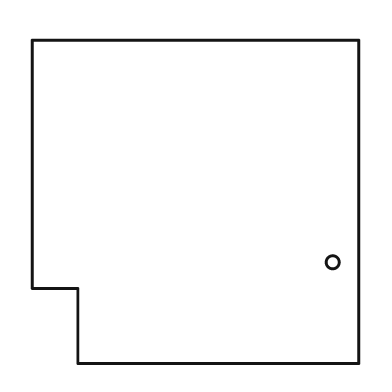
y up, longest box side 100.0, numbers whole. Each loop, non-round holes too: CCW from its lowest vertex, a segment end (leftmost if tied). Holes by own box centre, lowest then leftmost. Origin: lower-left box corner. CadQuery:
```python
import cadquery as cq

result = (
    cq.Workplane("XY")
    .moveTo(14.0, 0.0)
    .lineTo(100.0, 0.0)
    .lineTo(100.0, 99.0)
    .lineTo(0.0, 99.0)
    .lineTo(0.0, 23.0)
    .lineTo(14.0, 23.0)
    .close()
    .moveTo(92.0, 31.0)
    .circle(2.0)
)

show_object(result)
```